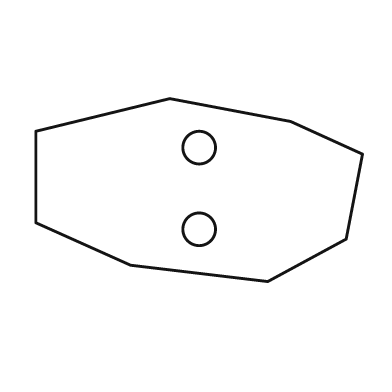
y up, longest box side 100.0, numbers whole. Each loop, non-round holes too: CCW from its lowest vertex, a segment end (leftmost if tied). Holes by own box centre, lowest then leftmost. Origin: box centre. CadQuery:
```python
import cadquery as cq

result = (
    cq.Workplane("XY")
    .moveTo(21.0, -28.0)
    .lineTo(45.0, -15.0)
    .lineTo(50.0, 11.0)
    .lineTo(28.0, 21.0)
    .lineTo(-9.0, 28.0)
    .lineTo(-50.0, 18.0)
    .lineTo(-50.0, -10.0)
    .lineTo(-21.0, -23.0)
    .close()
    .moveTo(0.0, -12.0)
    .circle(5.0)
    .moveTo(0.0, 13.0)
    .circle(5.0)
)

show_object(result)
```